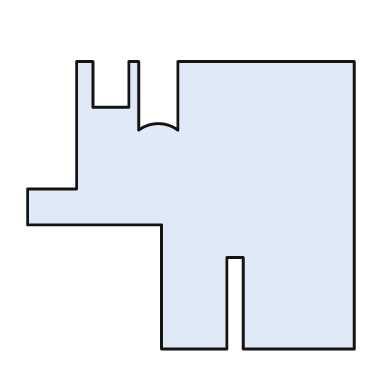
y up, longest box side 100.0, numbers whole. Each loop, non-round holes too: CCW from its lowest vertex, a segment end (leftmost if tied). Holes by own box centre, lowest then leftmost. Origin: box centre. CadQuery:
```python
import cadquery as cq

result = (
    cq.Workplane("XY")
    .moveTo(-9.0, -44.0)
    .lineTo(11.0, -44.0)
    .lineTo(11.0, -16.0)
    .lineTo(16.0, -16.0)
    .lineTo(16.0, -44.0)
    .lineTo(50.0, -44.0)
    .lineTo(50.0, 44.0)
    .lineTo(-4.0, 44.0)
    .lineTo(-4.0, 23.0)
    .threePointArc((-10.0, 25.0), (-16.0, 23.0))
    .lineTo(-16.0, 44.0)
    .lineTo(-19.0, 44.0)
    .lineTo(-19.0, 30.0)
    .lineTo(-30.0, 30.0)
    .lineTo(-30.0, 44.0)
    .lineTo(-35.0, 44.0)
    .lineTo(-35.0, 5.0)
    .lineTo(-50.0, 5.0)
    .lineTo(-50.0, -6.0)
    .lineTo(-9.0, -6.0)
    .close()
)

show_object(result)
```